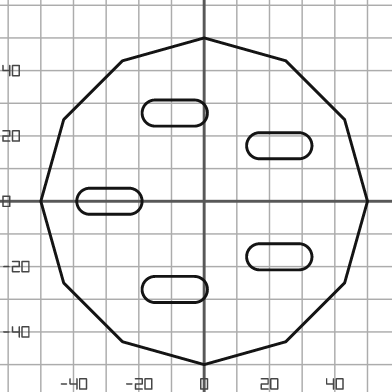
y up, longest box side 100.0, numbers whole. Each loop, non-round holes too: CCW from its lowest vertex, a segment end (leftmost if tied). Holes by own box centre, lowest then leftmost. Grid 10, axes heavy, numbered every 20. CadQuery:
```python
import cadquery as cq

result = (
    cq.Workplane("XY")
    .moveTo(0.0, -50.0)
    .lineTo(25.0, -43.0)
    .lineTo(43.0, -25.0)
    .lineTo(50.0, 0.0)
    .lineTo(43.0, 25.0)
    .lineTo(25.0, 43.0)
    .lineTo(0.0, 50.0)
    .lineTo(-25.0, 43.0)
    .lineTo(-43.0, 25.0)
    .lineTo(-50.0, 0.0)
    .lineTo(-43.0, -25.0)
    .lineTo(-25.0, -43.0)
    .close()
    .moveTo(-15.0, -31.0)
    .lineTo(-3.0, -31.0)
    .threePointArc((1.0, -27.0), (-3.0, -23.0))
    .lineTo(-15.0, -23.0)
    .threePointArc((-19.0, -27.0), (-15.0, -31.0))
    .close()
    .moveTo(17.0, -21.0)
    .lineTo(29.0, -21.0)
    .threePointArc((33.0, -17.0), (29.0, -13.0))
    .lineTo(17.0, -13.0)
    .threePointArc((13.0, -17.0), (17.0, -21.0))
    .close()
    .moveTo(-35.0, -4.0)
    .lineTo(-23.0, -4.0)
    .threePointArc((-19.0, 0.0), (-23.0, 4.0))
    .lineTo(-35.0, 4.0)
    .threePointArc((-39.0, 0.0), (-35.0, -4.0))
    .close()
    .moveTo(17.0, 13.0)
    .lineTo(29.0, 13.0)
    .threePointArc((33.0, 17.0), (29.0, 21.0))
    .lineTo(17.0, 21.0)
    .threePointArc((13.0, 17.0), (17.0, 13.0))
    .close()
    .moveTo(-15.0, 23.0)
    .lineTo(-3.0, 23.0)
    .threePointArc((1.0, 27.0), (-3.0, 31.0))
    .lineTo(-15.0, 31.0)
    .threePointArc((-19.0, 27.0), (-15.0, 23.0))
    .close()
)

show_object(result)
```